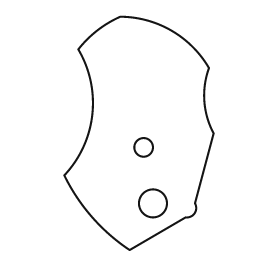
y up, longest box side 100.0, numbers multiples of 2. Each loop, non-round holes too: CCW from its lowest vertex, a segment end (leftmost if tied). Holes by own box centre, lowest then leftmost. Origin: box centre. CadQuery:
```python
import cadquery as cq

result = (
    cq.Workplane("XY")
    .moveTo(-4.0, -50.0)
    .lineTo(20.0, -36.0)
    .threePointArc((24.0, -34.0), (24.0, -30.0))
    .lineTo(32.0, 0.0)
    .threePointArc((28.0, 14.0), (30.0, 28.0))
    .threePointArc((14.0, 44.0), (-8.0, 50.0))
    .threePointArc((-18.0, 44.0), (-26.0, 36.0))
    .threePointArc((-20.0, 8.0), (-32.0, -18.0))
    .threePointArc((-20.0, -36.0), (-4.0, -50.0))
    .close()
    .moveTo(6.0, -30.0)
    .circle(6.0)
    .moveTo(2.0, -6.0)
    .circle(4.0)
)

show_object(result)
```